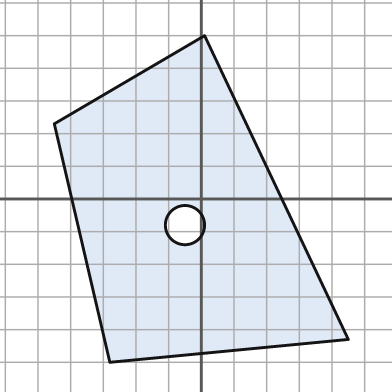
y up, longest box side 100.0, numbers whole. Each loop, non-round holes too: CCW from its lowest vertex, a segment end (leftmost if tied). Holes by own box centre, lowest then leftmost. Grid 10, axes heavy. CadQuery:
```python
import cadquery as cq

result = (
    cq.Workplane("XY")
    .moveTo(-28.0, -50.0)
    .lineTo(45.0, -43.0)
    .lineTo(1.0, 50.0)
    .lineTo(-45.0, 23.0)
    .close()
    .moveTo(-5.0, -8.0)
    .circle(6.0)
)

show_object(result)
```